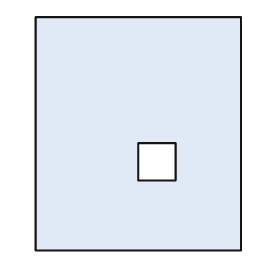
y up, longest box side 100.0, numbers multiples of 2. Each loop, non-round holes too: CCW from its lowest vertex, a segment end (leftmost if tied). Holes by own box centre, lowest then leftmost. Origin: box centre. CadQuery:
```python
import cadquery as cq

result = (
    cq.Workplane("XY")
    .moveTo(-44.0, -50.0)
    .lineTo(44.0, -50.0)
    .lineTo(44.0, 50.0)
    .lineTo(-44.0, 50.0)
    .close()
    .moveTo(0.0, -20.0)
    .lineTo(16.0, -20.0)
    .lineTo(16.0, -4.0)
    .lineTo(0.0, -4.0)
    .close()
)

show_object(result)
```